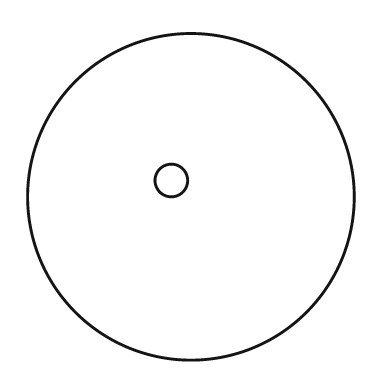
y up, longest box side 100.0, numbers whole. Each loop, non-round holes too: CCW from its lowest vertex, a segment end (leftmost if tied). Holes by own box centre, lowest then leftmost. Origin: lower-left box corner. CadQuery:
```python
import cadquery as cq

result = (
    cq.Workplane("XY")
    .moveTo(50.0, 50.0)
    .circle(50.0)
    .moveTo(44.0, 55.0)
    .circle(5.0)
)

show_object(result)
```